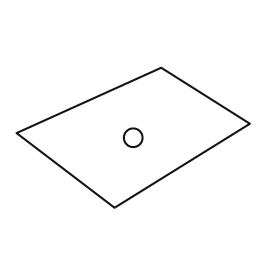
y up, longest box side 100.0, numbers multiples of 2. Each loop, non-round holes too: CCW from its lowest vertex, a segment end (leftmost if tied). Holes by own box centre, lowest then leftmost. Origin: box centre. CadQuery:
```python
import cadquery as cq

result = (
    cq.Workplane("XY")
    .moveTo(-8.0, -30.0)
    .lineTo(50.0, 6.0)
    .lineTo(12.0, 30.0)
    .lineTo(-50.0, 2.0)
    .close()
    .moveTo(0.0, 0.0)
    .circle(4.0)
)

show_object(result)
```